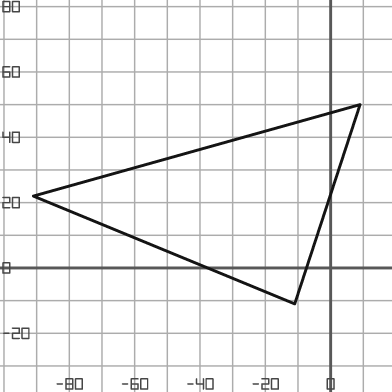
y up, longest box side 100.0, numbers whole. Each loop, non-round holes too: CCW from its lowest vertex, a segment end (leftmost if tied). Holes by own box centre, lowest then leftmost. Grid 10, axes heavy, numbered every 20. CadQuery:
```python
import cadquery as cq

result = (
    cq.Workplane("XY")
    .moveTo(-11.0, -11.0)
    .lineTo(9.0, 50.0)
    .lineTo(-91.0, 22.0)
    .close()
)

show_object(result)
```